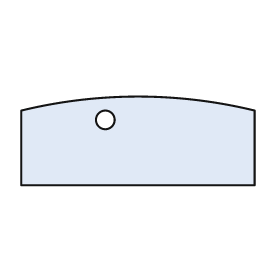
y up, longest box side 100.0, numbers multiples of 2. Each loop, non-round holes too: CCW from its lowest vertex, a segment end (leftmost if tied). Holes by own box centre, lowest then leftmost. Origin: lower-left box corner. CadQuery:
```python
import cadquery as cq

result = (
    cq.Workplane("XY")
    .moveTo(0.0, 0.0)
    .lineTo(100.0, 0.0)
    .lineTo(100.0, 32.0)
    .threePointArc((50.0, 38.0), (0.0, 32.0))
    .close()
    .moveTo(36.0, 28.0)
    .circle(4.0)
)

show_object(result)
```